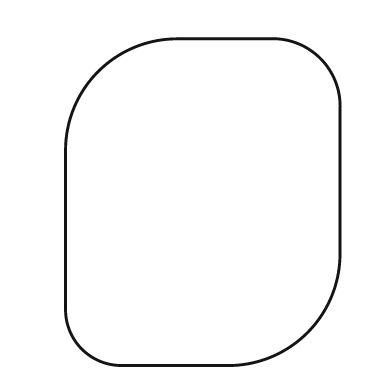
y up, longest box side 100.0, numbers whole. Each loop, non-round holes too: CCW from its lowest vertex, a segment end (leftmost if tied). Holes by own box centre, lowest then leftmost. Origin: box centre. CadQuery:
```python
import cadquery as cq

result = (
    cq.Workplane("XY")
    .moveTo(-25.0, -50.0)
    .lineTo(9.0, -50.0)
    .threePointArc((32.0, -40.0), (42.0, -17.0))
    .lineTo(42.0, 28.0)
    .threePointArc((36.0, 44.0), (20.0, 50.0))
    .lineTo(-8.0, 50.0)
    .threePointArc((-32.0, 40.0), (-42.0, 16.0))
    .lineTo(-42.0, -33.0)
    .threePointArc((-37.0, -45.0), (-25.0, -50.0))
    .close()
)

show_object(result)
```